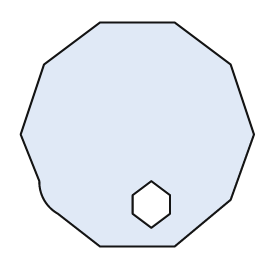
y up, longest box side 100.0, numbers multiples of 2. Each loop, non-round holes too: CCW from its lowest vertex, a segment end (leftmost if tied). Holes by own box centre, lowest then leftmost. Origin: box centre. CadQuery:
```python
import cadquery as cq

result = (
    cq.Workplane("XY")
    .moveTo(-16.0, -48.0)
    .lineTo(16.0, -48.0)
    .lineTo(40.0, -28.0)
    .lineTo(50.0, 0.0)
    .lineTo(40.0, 30.0)
    .lineTo(16.0, 48.0)
    .lineTo(-16.0, 48.0)
    .lineTo(-40.0, 30.0)
    .lineTo(-50.0, 0.0)
    .lineTo(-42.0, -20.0)
    .threePointArc((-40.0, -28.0), (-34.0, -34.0))
    .close()
    .moveTo(6.0, -40.0)
    .lineTo(14.0, -34.0)
    .lineTo(14.0, -26.0)
    .lineTo(6.0, -20.0)
    .lineTo(-2.0, -26.0)
    .lineTo(-2.0, -34.0)
    .close()
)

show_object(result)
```